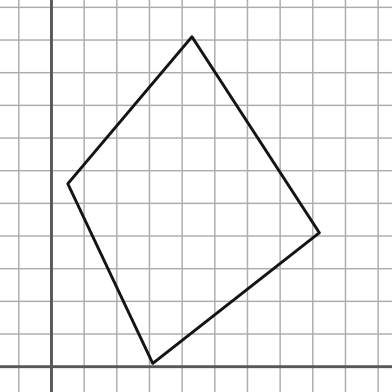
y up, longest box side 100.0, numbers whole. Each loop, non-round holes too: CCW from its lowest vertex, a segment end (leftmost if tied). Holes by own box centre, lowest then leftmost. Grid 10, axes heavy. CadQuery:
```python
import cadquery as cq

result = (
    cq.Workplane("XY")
    .moveTo(31.0, 1.0)
    .lineTo(82.0, 41.0)
    .lineTo(43.0, 101.0)
    .lineTo(5.0, 56.0)
    .close()
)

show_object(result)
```